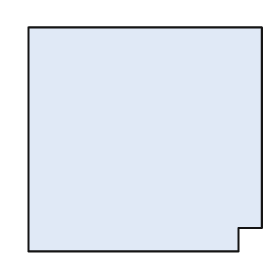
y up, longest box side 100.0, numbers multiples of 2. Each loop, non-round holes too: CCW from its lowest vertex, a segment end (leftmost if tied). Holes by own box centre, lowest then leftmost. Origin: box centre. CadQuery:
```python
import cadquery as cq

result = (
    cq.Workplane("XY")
    .moveTo(-50.0, -48.0)
    .lineTo(40.0, -48.0)
    .lineTo(40.0, -38.0)
    .lineTo(50.0, -38.0)
    .lineTo(50.0, 48.0)
    .lineTo(-50.0, 48.0)
    .close()
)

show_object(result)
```